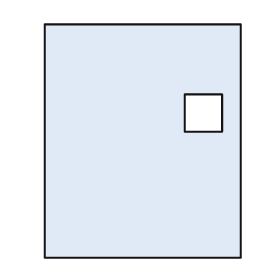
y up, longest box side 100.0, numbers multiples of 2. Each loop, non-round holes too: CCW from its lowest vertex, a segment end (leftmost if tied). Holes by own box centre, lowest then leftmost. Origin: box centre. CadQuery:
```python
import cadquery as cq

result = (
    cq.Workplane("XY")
    .moveTo(-42.0, -50.0)
    .lineTo(42.0, -50.0)
    .lineTo(42.0, 50.0)
    .lineTo(-42.0, 50.0)
    .close()
    .moveTo(18.0, 4.0)
    .lineTo(34.0, 4.0)
    .lineTo(34.0, 20.0)
    .lineTo(18.0, 20.0)
    .close()
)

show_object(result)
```